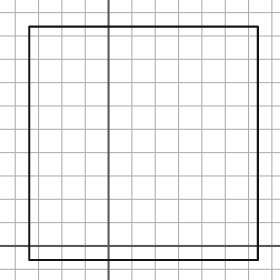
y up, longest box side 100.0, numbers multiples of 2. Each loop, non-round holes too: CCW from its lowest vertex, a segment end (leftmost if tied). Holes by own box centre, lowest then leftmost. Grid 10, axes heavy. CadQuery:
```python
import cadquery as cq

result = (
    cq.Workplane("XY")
    .moveTo(-34.0, -6.0)
    .lineTo(64.0, -6.0)
    .lineTo(64.0, 94.0)
    .lineTo(-34.0, 94.0)
    .close()
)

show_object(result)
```